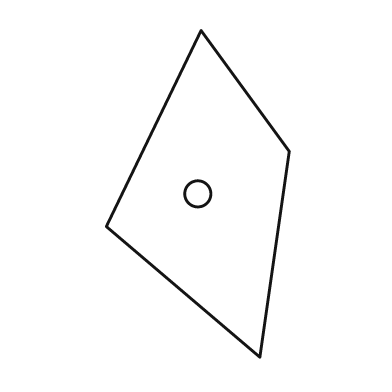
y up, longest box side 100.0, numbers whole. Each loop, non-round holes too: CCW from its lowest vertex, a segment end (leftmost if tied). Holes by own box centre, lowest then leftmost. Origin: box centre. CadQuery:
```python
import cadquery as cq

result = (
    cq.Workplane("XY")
    .moveTo(19.0, -50.0)
    .lineTo(28.0, 13.0)
    .lineTo(1.0, 50.0)
    .lineTo(-28.0, -10.0)
    .close()
    .moveTo(0.0, 0.0)
    .circle(4.0)
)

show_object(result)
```